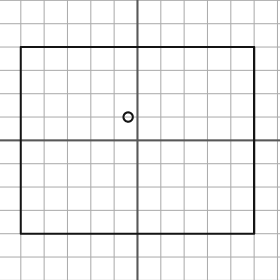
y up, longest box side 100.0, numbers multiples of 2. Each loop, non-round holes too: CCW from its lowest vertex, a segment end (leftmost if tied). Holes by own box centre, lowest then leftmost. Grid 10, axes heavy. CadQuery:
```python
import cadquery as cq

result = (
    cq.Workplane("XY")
    .moveTo(-50.0, -40.0)
    .lineTo(50.0, -40.0)
    .lineTo(50.0, 40.0)
    .lineTo(-50.0, 40.0)
    .close()
    .moveTo(-4.0, 10.0)
    .circle(2.0)
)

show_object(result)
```